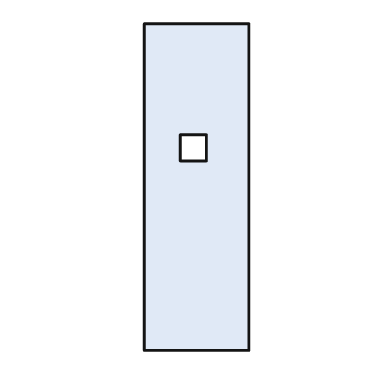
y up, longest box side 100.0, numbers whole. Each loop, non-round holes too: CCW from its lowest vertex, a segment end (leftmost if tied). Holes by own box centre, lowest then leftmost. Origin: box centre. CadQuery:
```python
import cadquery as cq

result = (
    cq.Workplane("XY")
    .moveTo(-16.0, -50.0)
    .lineTo(16.0, -50.0)
    .lineTo(16.0, 50.0)
    .lineTo(-16.0, 50.0)
    .close()
    .moveTo(-5.0, 8.0)
    .lineTo(3.0, 8.0)
    .lineTo(3.0, 16.0)
    .lineTo(-5.0, 16.0)
    .close()
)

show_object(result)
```